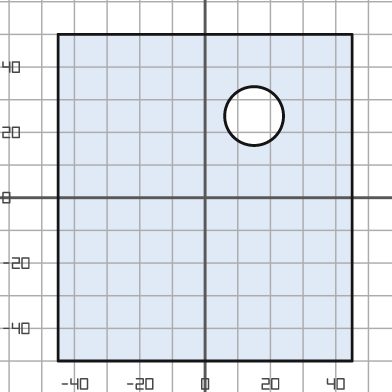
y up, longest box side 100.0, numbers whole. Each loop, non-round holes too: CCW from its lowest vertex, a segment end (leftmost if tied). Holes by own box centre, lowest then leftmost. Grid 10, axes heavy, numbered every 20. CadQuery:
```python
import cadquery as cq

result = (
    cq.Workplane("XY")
    .moveTo(-45.0, -50.0)
    .lineTo(45.0, -50.0)
    .lineTo(45.0, 50.0)
    .lineTo(-45.0, 50.0)
    .close()
    .moveTo(15.0, 25.0)
    .circle(9.0)
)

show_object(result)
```